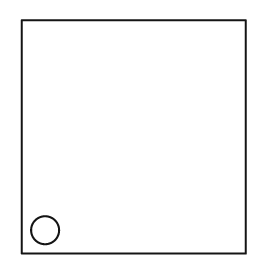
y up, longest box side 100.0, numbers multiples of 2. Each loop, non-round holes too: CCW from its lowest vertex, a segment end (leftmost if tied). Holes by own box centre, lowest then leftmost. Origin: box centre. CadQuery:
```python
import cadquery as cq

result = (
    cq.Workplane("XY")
    .moveTo(-48.0, -50.0)
    .lineTo(48.0, -50.0)
    .lineTo(48.0, 50.0)
    .lineTo(-48.0, 50.0)
    .close()
    .moveTo(-38.0, -40.0)
    .circle(6.0)
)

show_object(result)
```